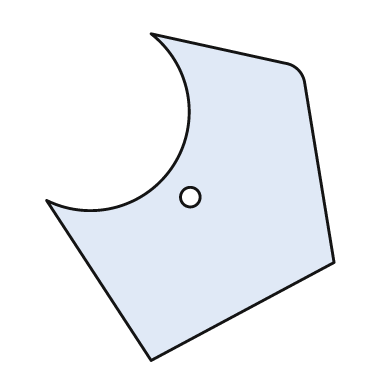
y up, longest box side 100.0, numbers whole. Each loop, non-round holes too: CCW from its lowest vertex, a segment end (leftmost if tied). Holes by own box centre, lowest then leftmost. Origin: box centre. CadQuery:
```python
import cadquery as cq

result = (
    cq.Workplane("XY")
    .moveTo(-12.0, -50.0)
    .lineTo(44.0, -20.0)
    .lineTo(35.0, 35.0)
    .threePointArc((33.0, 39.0), (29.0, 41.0))
    .lineTo(-12.0, 50.0)
    .threePointArc((-5.0, 10.0), (-44.0, -1.0))
    .close()
    .moveTo(0.0, 0.0)
    .circle(3.0)
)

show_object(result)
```